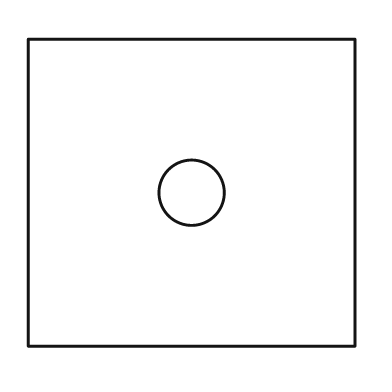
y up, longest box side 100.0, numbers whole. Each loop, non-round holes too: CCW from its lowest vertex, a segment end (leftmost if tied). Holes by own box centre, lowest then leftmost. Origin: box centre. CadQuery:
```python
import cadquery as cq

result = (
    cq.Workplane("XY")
    .moveTo(-50.0, -47.0)
    .lineTo(50.0, -47.0)
    .lineTo(50.0, 47.0)
    .lineTo(-50.0, 47.0)
    .close()
    .moveTo(0.0, 0.0)
    .circle(10.0)
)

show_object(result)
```